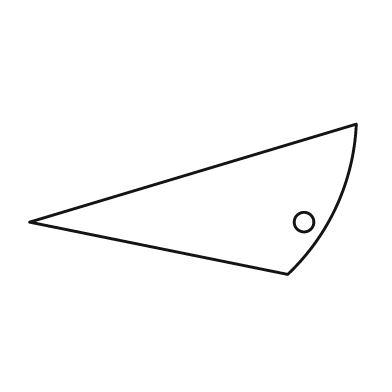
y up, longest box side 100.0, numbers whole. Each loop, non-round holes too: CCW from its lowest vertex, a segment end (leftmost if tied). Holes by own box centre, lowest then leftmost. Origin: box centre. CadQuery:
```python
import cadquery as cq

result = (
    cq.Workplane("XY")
    .moveTo(29.0, -23.0)
    .threePointArc((44.0, -2.0), (50.0, 23.0))
    .lineTo(-50.0, -7.0)
    .close()
    .moveTo(34.0, -7.0)
    .circle(3.0)
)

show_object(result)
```